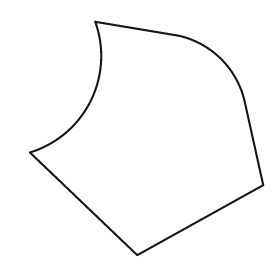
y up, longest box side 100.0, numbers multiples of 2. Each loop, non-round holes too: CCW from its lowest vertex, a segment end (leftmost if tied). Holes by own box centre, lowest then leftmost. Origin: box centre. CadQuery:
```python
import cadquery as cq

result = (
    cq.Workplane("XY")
    .moveTo(-4.0, -50.0)
    .lineTo(50.0, -20.0)
    .lineTo(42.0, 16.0)
    .threePointArc((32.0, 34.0), (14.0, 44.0))
    .lineTo(-22.0, 50.0)
    .threePointArc((-24.0, 16.0), (-50.0, -6.0))
    .close()
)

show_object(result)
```